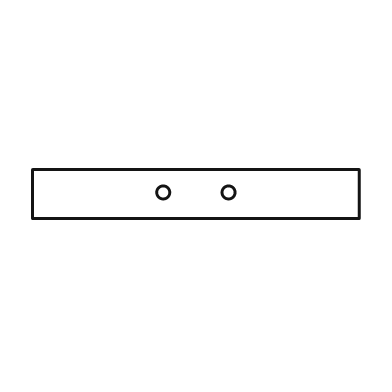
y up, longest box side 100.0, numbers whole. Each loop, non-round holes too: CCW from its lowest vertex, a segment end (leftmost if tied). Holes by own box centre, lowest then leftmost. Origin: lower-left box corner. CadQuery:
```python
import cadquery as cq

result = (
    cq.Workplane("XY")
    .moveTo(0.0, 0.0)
    .lineTo(100.0, 0.0)
    .lineTo(100.0, 15.0)
    .lineTo(0.0, 15.0)
    .close()
    .moveTo(40.0, 8.0)
    .circle(2.0)
    .moveTo(60.0, 8.0)
    .circle(2.0)
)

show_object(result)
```